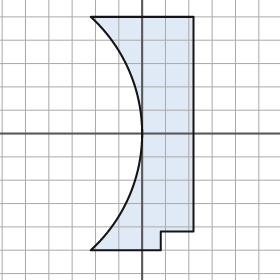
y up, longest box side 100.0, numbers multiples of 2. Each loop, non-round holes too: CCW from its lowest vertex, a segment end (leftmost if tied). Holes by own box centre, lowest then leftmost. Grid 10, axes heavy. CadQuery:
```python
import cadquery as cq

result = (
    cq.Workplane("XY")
    .moveTo(-22.0, -50.0)
    .lineTo(8.0, -50.0)
    .lineTo(8.0, -42.0)
    .lineTo(22.0, -42.0)
    .lineTo(22.0, 50.0)
    .lineTo(-22.0, 50.0)
    .threePointArc((0.0, 0.0), (-22.0, -50.0))
    .close()
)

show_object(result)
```